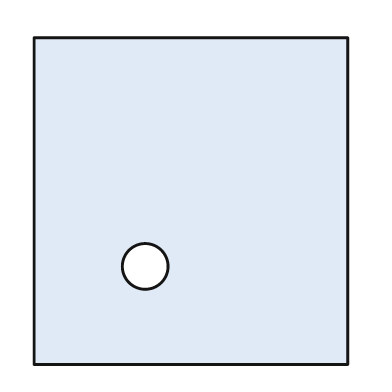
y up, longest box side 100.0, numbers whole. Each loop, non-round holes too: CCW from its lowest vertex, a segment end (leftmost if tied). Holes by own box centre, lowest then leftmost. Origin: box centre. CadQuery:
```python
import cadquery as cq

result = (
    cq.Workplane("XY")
    .moveTo(-48.0, -50.0)
    .lineTo(48.0, -50.0)
    .lineTo(48.0, 50.0)
    .lineTo(-48.0, 50.0)
    .close()
    .moveTo(-14.0, -20.0)
    .circle(7.0)
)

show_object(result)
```